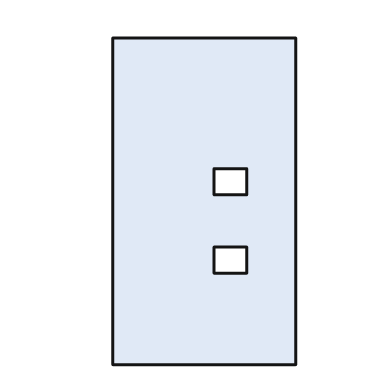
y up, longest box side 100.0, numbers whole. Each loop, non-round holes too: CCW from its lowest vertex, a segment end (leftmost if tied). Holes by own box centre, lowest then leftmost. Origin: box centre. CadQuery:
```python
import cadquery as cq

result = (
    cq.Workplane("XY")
    .moveTo(-28.0, -50.0)
    .lineTo(28.0, -50.0)
    .lineTo(28.0, 50.0)
    .lineTo(-28.0, 50.0)
    .close()
    .moveTo(3.0, -22.0)
    .lineTo(13.0, -22.0)
    .lineTo(13.0, -14.0)
    .lineTo(3.0, -14.0)
    .close()
    .moveTo(3.0, 2.0)
    .lineTo(13.0, 2.0)
    .lineTo(13.0, 10.0)
    .lineTo(3.0, 10.0)
    .close()
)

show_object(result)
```